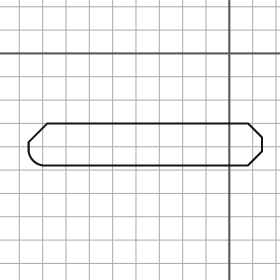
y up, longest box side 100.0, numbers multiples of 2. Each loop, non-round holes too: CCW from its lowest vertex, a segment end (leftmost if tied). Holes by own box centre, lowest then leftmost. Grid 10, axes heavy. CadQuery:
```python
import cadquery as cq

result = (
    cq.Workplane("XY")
    .moveTo(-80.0, -48.0)
    .lineTo(8.0, -48.0)
    .lineTo(14.0, -42.0)
    .lineTo(14.0, -36.0)
    .lineTo(8.0, -30.0)
    .lineTo(-78.0, -30.0)
    .lineTo(-86.0, -38.0)
    .lineTo(-86.0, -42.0)
    .threePointArc((-84.0, -46.0), (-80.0, -48.0))
    .close()
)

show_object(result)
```